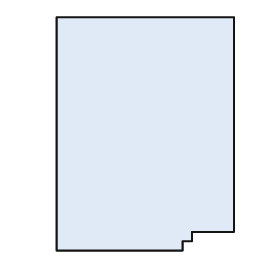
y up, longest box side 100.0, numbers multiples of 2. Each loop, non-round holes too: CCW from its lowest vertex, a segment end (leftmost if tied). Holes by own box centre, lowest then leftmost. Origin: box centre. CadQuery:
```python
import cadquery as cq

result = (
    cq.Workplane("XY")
    .moveTo(-38.0, -50.0)
    .lineTo(16.0, -50.0)
    .lineTo(16.0, -46.0)
    .lineTo(20.0, -46.0)
    .lineTo(20.0, -42.0)
    .lineTo(38.0, -42.0)
    .lineTo(38.0, 50.0)
    .lineTo(-38.0, 50.0)
    .close()
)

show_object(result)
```